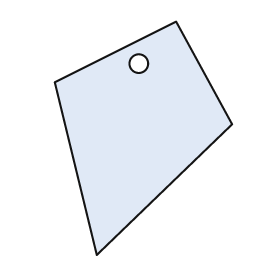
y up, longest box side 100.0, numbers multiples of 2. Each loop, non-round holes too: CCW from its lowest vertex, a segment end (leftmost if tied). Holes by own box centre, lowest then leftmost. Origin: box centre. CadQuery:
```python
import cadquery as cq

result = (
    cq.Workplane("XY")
    .moveTo(-20.0, -50.0)
    .lineTo(38.0, 6.0)
    .lineTo(14.0, 50.0)
    .lineTo(-38.0, 24.0)
    .close()
    .moveTo(-2.0, 32.0)
    .circle(4.0)
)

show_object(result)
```